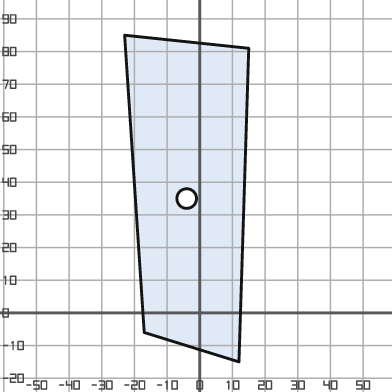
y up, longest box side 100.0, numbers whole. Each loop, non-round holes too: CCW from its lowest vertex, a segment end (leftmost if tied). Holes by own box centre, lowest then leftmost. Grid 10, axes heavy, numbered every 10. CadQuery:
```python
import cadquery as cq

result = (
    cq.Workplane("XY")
    .moveTo(12.0, -15.0)
    .lineTo(15.0, 81.0)
    .lineTo(-23.0, 85.0)
    .lineTo(-17.0, -6.0)
    .close()
    .moveTo(-4.0, 35.0)
    .circle(3.0)
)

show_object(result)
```